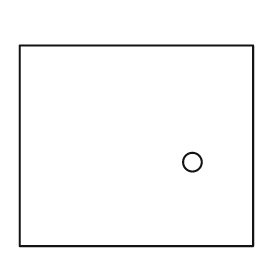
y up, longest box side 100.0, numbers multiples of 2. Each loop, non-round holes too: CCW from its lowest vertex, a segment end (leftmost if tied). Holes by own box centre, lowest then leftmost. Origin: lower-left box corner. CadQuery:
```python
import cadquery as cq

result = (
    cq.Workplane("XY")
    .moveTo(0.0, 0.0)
    .lineTo(100.0, 0.0)
    .lineTo(100.0, 86.0)
    .lineTo(0.0, 86.0)
    .close()
    .moveTo(74.0, 36.0)
    .circle(4.0)
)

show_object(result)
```